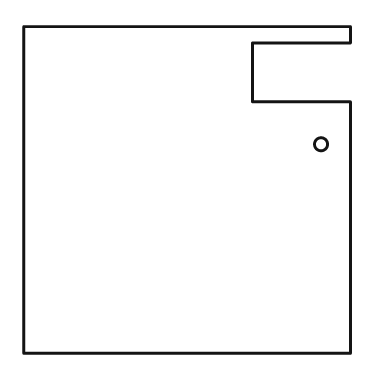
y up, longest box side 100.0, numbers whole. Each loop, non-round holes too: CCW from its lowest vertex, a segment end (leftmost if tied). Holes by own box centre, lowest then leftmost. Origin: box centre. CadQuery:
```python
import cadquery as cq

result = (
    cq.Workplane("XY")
    .moveTo(-50.0, -50.0)
    .lineTo(50.0, -50.0)
    .lineTo(50.0, 27.0)
    .lineTo(20.0, 27.0)
    .lineTo(20.0, 45.0)
    .lineTo(50.0, 45.0)
    .lineTo(50.0, 50.0)
    .lineTo(-50.0, 50.0)
    .close()
    .moveTo(41.0, 14.0)
    .circle(2.0)
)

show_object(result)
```